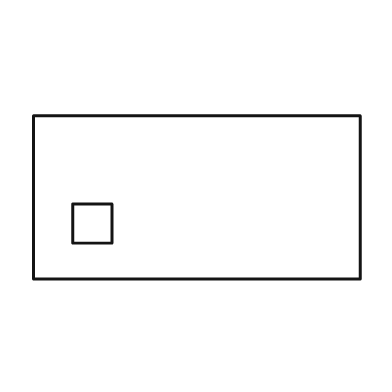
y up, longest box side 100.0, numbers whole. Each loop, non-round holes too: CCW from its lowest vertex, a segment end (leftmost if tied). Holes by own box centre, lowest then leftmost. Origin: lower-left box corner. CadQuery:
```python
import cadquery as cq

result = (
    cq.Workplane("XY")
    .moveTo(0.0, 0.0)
    .lineTo(100.0, 0.0)
    .lineTo(100.0, 50.0)
    .lineTo(0.0, 50.0)
    .close()
    .moveTo(12.0, 11.0)
    .lineTo(24.0, 11.0)
    .lineTo(24.0, 23.0)
    .lineTo(12.0, 23.0)
    .close()
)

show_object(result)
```